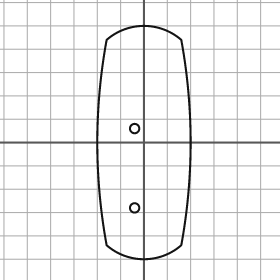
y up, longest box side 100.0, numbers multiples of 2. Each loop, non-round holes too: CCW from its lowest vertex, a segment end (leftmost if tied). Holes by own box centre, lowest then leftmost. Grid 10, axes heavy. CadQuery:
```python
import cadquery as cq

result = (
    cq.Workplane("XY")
    .moveTo(-16.0, -44.0)
    .threePointArc((0.0, -50.0), (16.0, -44.0))
    .threePointArc((20.0, 0.0), (16.0, 44.0))
    .threePointArc((0.0, 50.0), (-16.0, 44.0))
    .threePointArc((-20.0, 0.0), (-16.0, -44.0))
    .close()
    .moveTo(-4.0, -28.0)
    .circle(2.0)
    .moveTo(-4.0, 6.0)
    .circle(2.0)
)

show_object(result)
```